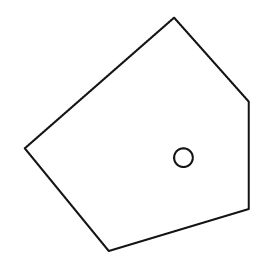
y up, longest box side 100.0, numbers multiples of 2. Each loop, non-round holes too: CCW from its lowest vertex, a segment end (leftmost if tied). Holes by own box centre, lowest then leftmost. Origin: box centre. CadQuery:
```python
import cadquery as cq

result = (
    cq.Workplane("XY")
    .moveTo(-12.0, -50.0)
    .lineTo(48.0, -32.0)
    .lineTo(48.0, 14.0)
    .lineTo(16.0, 50.0)
    .lineTo(-48.0, -6.0)
    .close()
    .moveTo(20.0, -10.0)
    .circle(4.0)
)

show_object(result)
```